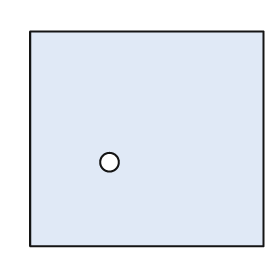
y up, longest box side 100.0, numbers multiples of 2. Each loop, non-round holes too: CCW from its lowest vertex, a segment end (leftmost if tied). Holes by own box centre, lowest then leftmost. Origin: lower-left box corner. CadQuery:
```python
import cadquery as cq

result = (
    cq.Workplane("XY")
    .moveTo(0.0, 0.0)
    .lineTo(100.0, 0.0)
    .lineTo(100.0, 92.0)
    .lineTo(0.0, 92.0)
    .close()
    .moveTo(34.0, 36.0)
    .circle(4.0)
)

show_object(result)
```